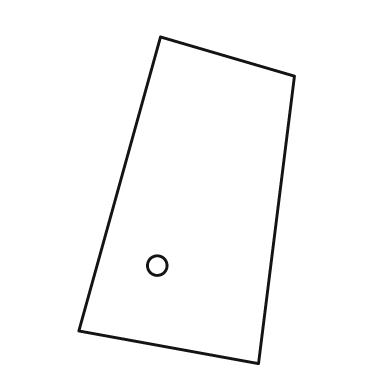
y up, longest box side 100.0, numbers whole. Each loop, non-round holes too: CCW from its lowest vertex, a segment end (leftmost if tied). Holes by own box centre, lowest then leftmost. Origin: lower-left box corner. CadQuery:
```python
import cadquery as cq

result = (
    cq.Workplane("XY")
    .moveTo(55.0, 0.0)
    .lineTo(66.0, 88.0)
    .lineTo(25.0, 100.0)
    .lineTo(0.0, 10.0)
    .close()
    .moveTo(24.0, 30.0)
    .circle(3.0)
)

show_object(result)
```